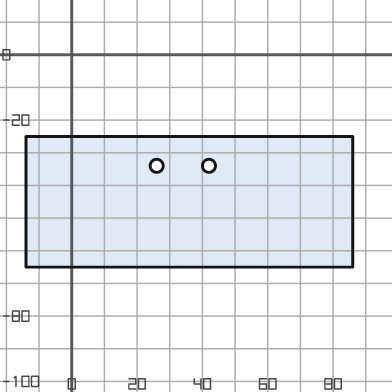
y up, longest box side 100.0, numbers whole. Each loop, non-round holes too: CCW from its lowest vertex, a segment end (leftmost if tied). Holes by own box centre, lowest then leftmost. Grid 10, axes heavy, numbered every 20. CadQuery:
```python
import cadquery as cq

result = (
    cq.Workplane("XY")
    .moveTo(-14.0, -65.0)
    .lineTo(86.0, -65.0)
    .lineTo(86.0, -25.0)
    .lineTo(-14.0, -25.0)
    .close()
    .moveTo(26.0, -34.0)
    .circle(2.0)
    .moveTo(42.0, -34.0)
    .circle(2.0)
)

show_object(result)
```